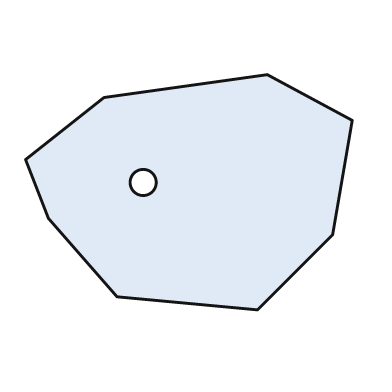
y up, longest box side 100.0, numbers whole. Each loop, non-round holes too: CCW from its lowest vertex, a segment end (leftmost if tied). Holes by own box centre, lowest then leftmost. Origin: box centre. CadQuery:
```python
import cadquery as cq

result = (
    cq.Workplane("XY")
    .moveTo(21.0, -36.0)
    .lineTo(44.0, -13.0)
    .lineTo(50.0, 22.0)
    .lineTo(24.0, 36.0)
    .lineTo(-26.0, 29.0)
    .lineTo(-50.0, 10.0)
    .lineTo(-43.0, -8.0)
    .lineTo(-22.0, -32.0)
    .close()
    .moveTo(-14.0, 3.0)
    .circle(4.0)
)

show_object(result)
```